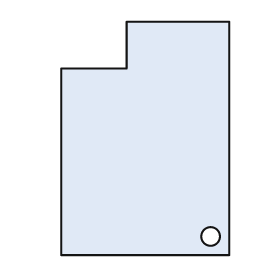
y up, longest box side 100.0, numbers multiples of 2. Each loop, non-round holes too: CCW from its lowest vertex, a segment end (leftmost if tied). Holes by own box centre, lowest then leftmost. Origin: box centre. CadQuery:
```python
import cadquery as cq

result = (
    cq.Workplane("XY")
    .moveTo(-36.0, -50.0)
    .lineTo(36.0, -50.0)
    .lineTo(36.0, 50.0)
    .lineTo(-8.0, 50.0)
    .lineTo(-8.0, 30.0)
    .lineTo(-36.0, 30.0)
    .close()
    .moveTo(28.0, -42.0)
    .circle(4.0)
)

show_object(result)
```